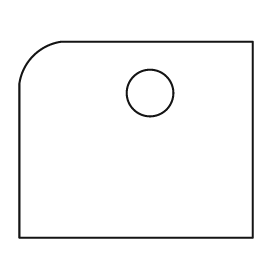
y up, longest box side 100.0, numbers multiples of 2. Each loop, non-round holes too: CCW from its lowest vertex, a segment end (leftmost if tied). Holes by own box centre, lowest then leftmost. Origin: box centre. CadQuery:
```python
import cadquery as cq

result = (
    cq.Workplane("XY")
    .moveTo(-50.0, -42.0)
    .lineTo(50.0, -42.0)
    .lineTo(50.0, 42.0)
    .lineTo(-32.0, 42.0)
    .threePointArc((-44.0, 36.0), (-50.0, 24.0))
    .close()
    .moveTo(6.0, 20.0)
    .circle(10.0)
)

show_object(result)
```